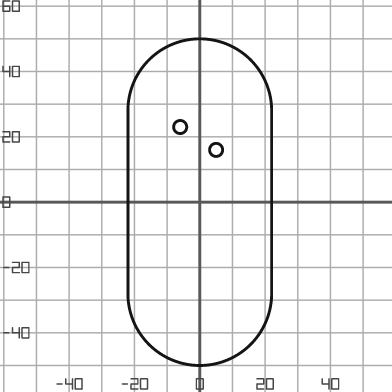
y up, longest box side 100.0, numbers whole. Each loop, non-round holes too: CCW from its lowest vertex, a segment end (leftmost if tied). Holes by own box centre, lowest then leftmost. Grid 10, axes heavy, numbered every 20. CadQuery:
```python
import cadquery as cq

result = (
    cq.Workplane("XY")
    .moveTo(-22.0, -28.0)
    .threePointArc((0.0, -50.0), (22.0, -28.0))
    .lineTo(22.0, 28.0)
    .threePointArc((0.0, 50.0), (-22.0, 28.0))
    .close()
    .moveTo(5.0, 16.0)
    .circle(2.0)
    .moveTo(-6.0, 23.0)
    .circle(2.0)
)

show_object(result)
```